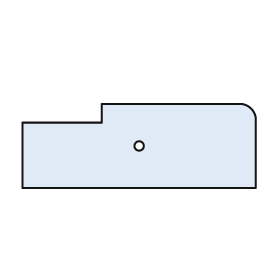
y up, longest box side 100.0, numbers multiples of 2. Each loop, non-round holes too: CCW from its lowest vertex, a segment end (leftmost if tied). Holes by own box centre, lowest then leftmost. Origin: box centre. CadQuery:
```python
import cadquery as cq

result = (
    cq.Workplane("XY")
    .moveTo(-50.0, -18.0)
    .lineTo(50.0, -18.0)
    .lineTo(50.0, 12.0)
    .threePointArc((48.0, 16.0), (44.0, 18.0))
    .lineTo(-16.0, 18.0)
    .lineTo(-16.0, 10.0)
    .lineTo(-50.0, 10.0)
    .close()
    .moveTo(0.0, 0.0)
    .circle(2.0)
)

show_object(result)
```